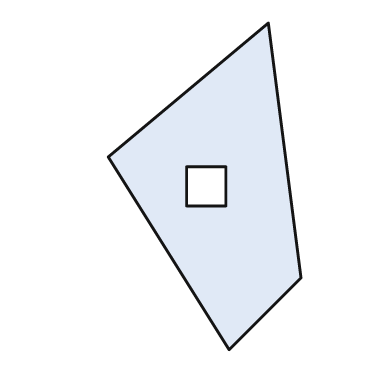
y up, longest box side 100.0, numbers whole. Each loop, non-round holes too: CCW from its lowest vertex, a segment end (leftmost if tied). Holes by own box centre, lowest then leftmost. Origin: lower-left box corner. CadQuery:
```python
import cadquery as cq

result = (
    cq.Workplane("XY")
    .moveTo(37.0, 0.0)
    .lineTo(59.0, 22.0)
    .lineTo(49.0, 100.0)
    .lineTo(0.0, 59.0)
    .close()
    .moveTo(24.0, 44.0)
    .lineTo(36.0, 44.0)
    .lineTo(36.0, 56.0)
    .lineTo(24.0, 56.0)
    .close()
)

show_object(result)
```